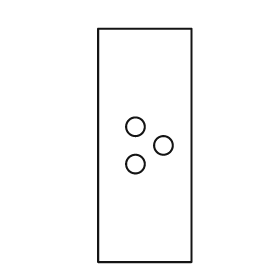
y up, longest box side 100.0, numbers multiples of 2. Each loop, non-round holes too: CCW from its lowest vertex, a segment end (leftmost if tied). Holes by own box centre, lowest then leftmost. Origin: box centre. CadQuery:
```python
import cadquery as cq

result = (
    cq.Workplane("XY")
    .moveTo(-20.0, -50.0)
    .lineTo(20.0, -50.0)
    .lineTo(20.0, 50.0)
    .lineTo(-20.0, 50.0)
    .close()
    .moveTo(-4.0, -8.0)
    .circle(4.0)
    .moveTo(8.0, 0.0)
    .circle(4.0)
    .moveTo(-4.0, 8.0)
    .circle(4.0)
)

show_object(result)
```